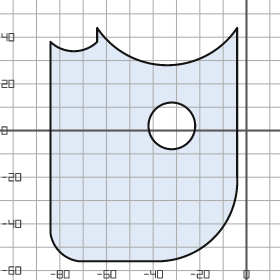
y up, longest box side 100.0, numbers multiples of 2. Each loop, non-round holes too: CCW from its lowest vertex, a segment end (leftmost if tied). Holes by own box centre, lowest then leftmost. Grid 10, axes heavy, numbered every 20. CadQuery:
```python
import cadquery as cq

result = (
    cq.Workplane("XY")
    .moveTo(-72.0, -56.0)
    .lineTo(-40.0, -56.0)
    .threePointArc((-14.0, -46.0), (-4.0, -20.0))
    .lineTo(-4.0, 44.0)
    .threePointArc((-34.0, 28.0), (-64.0, 44.0))
    .lineTo(-64.0, 38.0)
    .threePointArc((-74.0, 34.0), (-84.0, 38.0))
    .lineTo(-84.0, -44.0)
    .threePointArc((-80.0, -52.0), (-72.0, -56.0))
    .close()
    .moveTo(-32.0, 2.0)
    .circle(10.0)
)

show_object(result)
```